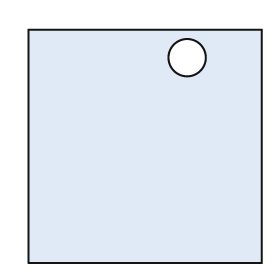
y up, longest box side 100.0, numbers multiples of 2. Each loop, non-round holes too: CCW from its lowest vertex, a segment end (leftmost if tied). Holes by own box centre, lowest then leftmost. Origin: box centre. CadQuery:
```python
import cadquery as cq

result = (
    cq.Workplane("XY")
    .moveTo(-50.0, -50.0)
    .lineTo(50.0, -50.0)
    .lineTo(50.0, 50.0)
    .lineTo(-50.0, 50.0)
    .close()
    .moveTo(18.0, 38.0)
    .circle(8.0)
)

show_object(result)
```